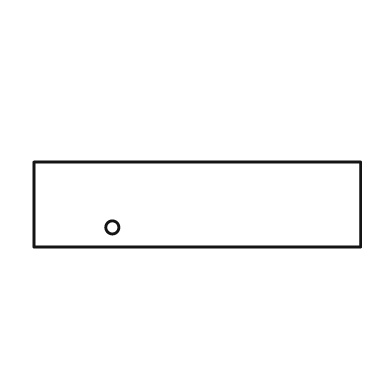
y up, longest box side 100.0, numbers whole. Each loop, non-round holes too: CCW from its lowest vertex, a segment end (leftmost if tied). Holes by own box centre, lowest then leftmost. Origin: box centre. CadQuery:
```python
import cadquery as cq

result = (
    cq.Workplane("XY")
    .moveTo(-50.0, -13.0)
    .lineTo(50.0, -13.0)
    .lineTo(50.0, 13.0)
    .lineTo(-50.0, 13.0)
    .close()
    .moveTo(-26.0, -7.0)
    .circle(2.0)
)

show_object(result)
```